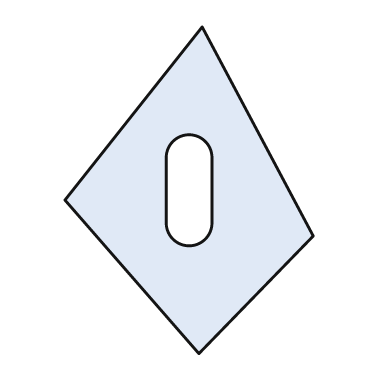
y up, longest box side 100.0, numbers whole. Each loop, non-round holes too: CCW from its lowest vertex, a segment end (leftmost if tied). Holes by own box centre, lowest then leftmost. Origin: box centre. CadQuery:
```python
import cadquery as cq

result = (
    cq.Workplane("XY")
    .moveTo(3.0, -50.0)
    .lineTo(38.0, -14.0)
    .lineTo(4.0, 50.0)
    .lineTo(-38.0, -3.0)
    .close()
    .moveTo(-7.0, -10.0)
    .threePointArc((0.0, -17.0), (7.0, -10.0))
    .lineTo(7.0, 10.0)
    .threePointArc((0.0, 17.0), (-7.0, 10.0))
    .close()
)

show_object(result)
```